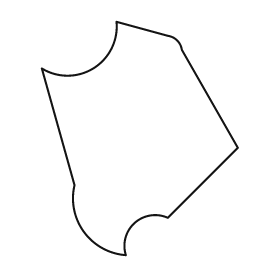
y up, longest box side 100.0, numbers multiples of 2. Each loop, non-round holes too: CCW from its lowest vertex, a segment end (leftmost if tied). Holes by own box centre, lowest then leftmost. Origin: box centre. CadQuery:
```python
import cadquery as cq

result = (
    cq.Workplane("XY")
    .moveTo(-6.0, -50.0)
    .threePointArc((-2.0, -36.0), (12.0, -34.0))
    .lineTo(42.0, -4.0)
    .lineTo(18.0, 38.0)
    .threePointArc((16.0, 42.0), (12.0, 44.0))
    .lineTo(-10.0, 50.0)
    .threePointArc((-20.0, 30.0), (-42.0, 30.0))
    .lineTo(-28.0, -20.0)
    .threePointArc((-24.0, -40.0), (-6.0, -50.0))
    .close()
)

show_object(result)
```